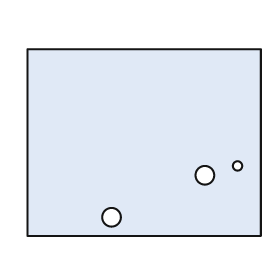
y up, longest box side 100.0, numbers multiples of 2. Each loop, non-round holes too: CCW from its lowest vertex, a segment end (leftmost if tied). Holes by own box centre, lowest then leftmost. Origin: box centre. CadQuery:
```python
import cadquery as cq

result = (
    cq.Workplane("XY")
    .moveTo(-50.0, -40.0)
    .lineTo(50.0, -40.0)
    .lineTo(50.0, 40.0)
    .lineTo(-50.0, 40.0)
    .close()
    .moveTo(-14.0, -32.0)
    .circle(4.0)
    .moveTo(26.0, -14.0)
    .circle(4.0)
    .moveTo(40.0, -10.0)
    .circle(2.0)
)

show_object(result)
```